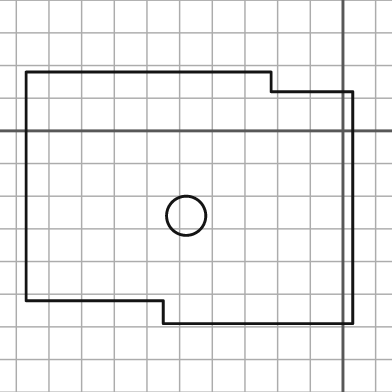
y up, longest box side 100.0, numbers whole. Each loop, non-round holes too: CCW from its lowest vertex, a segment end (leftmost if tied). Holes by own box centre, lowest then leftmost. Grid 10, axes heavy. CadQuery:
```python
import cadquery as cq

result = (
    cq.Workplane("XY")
    .moveTo(-55.0, -59.0)
    .lineTo(3.0, -59.0)
    .lineTo(3.0, 12.0)
    .lineTo(-22.0, 12.0)
    .lineTo(-22.0, 18.0)
    .lineTo(-97.0, 18.0)
    .lineTo(-97.0, -52.0)
    .lineTo(-55.0, -52.0)
    .close()
    .moveTo(-48.0, -26.0)
    .circle(6.0)
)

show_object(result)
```